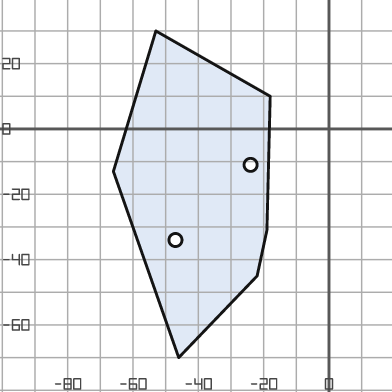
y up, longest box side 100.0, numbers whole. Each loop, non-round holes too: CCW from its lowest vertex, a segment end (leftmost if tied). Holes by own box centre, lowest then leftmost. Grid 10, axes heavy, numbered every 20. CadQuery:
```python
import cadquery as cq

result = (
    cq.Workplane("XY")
    .moveTo(-46.0, -70.0)
    .lineTo(-22.0, -45.0)
    .lineTo(-19.0, -31.0)
    .lineTo(-18.0, 10.0)
    .lineTo(-53.0, 30.0)
    .lineTo(-66.0, -13.0)
    .close()
    .moveTo(-47.0, -34.0)
    .circle(2.0)
    .moveTo(-24.0, -11.0)
    .circle(2.0)
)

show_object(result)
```